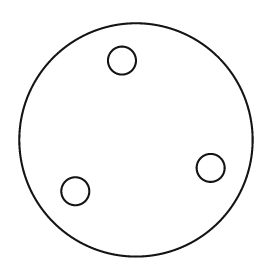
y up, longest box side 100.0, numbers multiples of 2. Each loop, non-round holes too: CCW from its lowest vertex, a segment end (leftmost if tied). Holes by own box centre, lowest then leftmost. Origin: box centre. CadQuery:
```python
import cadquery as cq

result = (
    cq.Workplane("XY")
    .moveTo(0.0, 0.0)
    .circle(50.0)
    .moveTo(-26.0, -22.0)
    .circle(6.0)
    .moveTo(32.0, -12.0)
    .circle(6.0)
    .moveTo(-6.0, 34.0)
    .circle(6.0)
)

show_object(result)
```